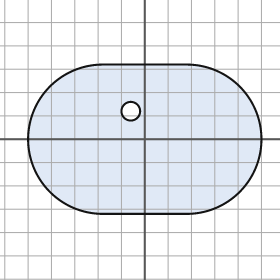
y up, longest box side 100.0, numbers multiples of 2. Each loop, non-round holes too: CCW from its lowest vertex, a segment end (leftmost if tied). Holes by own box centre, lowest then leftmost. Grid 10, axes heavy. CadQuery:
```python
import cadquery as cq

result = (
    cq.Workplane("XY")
    .moveTo(-18.0, -32.0)
    .lineTo(18.0, -32.0)
    .threePointArc((50.0, 0.0), (18.0, 32.0))
    .lineTo(-18.0, 32.0)
    .threePointArc((-50.0, 0.0), (-18.0, -32.0))
    .close()
    .moveTo(-6.0, 12.0)
    .circle(4.0)
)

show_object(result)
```